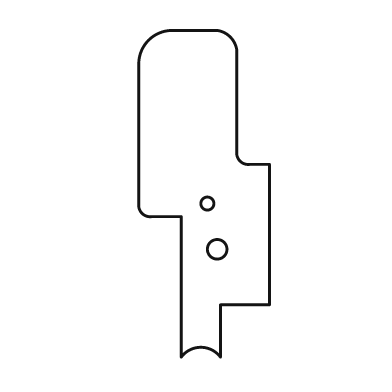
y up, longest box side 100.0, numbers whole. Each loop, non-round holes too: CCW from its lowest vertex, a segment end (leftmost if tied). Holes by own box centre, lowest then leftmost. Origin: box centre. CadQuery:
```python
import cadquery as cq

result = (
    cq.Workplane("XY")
    .moveTo(-7.0, -50.0)
    .threePointArc((-1.0, -47.0), (5.0, -50.0))
    .lineTo(5.0, -34.0)
    .lineTo(20.0, -34.0)
    .lineTo(20.0, 9.0)
    .lineTo(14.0, 9.0)
    .threePointArc((11.0, 10.0), (10.0, 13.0))
    .lineTo(10.0, 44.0)
    .threePointArc((8.0, 48.0), (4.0, 50.0))
    .lineTo(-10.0, 50.0)
    .threePointArc((-17.0, 47.0), (-20.0, 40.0))
    .lineTo(-20.0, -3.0)
    .threePointArc((-19.0, -6.0), (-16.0, -7.0))
    .lineTo(-7.0, -7.0)
    .close()
    .moveTo(4.0, -17.0)
    .circle(3.0)
    .moveTo(1.0, -3.0)
    .circle(2.0)
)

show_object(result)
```